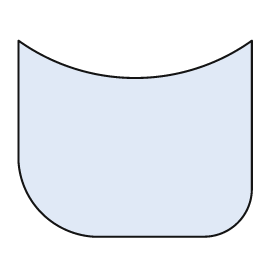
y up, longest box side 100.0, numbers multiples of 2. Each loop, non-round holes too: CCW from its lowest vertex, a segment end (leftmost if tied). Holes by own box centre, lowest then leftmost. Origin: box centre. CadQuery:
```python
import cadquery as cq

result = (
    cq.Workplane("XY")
    .moveTo(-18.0, -42.0)
    .lineTo(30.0, -42.0)
    .threePointArc((44.0, -36.0), (50.0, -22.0))
    .lineTo(50.0, 42.0)
    .threePointArc((0.0, 26.0), (-50.0, 42.0))
    .lineTo(-50.0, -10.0)
    .threePointArc((-40.0, -32.0), (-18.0, -42.0))
    .close()
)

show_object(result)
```